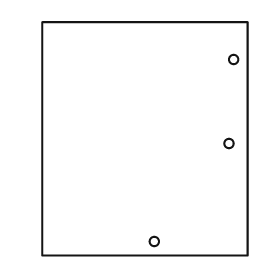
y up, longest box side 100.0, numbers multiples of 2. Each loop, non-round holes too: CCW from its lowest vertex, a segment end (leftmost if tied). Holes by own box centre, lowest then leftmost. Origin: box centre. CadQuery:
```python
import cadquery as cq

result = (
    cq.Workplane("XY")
    .moveTo(-44.0, -50.0)
    .lineTo(44.0, -50.0)
    .lineTo(44.0, 50.0)
    .lineTo(-44.0, 50.0)
    .close()
    .moveTo(4.0, -44.0)
    .circle(2.0)
    .moveTo(36.0, -2.0)
    .circle(2.0)
    .moveTo(38.0, 34.0)
    .circle(2.0)
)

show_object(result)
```